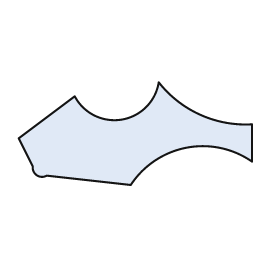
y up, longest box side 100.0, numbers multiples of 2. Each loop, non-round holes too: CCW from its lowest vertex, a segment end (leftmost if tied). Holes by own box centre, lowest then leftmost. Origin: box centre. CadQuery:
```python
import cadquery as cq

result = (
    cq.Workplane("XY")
    .moveTo(-2.0, -22.0)
    .threePointArc((22.0, -6.0), (50.0, -12.0))
    .lineTo(50.0, 4.0)
    .threePointArc((28.0, 8.0), (10.0, 22.0))
    .threePointArc((-6.0, 6.0), (-26.0, 16.0))
    .lineTo(-50.0, -2.0)
    .lineTo(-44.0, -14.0)
    .threePointArc((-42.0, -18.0), (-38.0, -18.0))
    .close()
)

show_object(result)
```